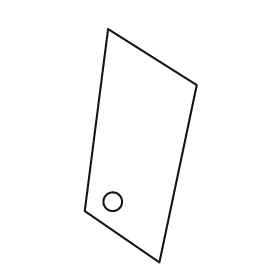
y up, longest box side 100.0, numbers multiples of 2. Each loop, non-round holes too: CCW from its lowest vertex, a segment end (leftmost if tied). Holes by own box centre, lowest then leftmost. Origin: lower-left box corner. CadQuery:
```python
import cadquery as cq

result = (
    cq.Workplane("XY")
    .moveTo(32.0, 0.0)
    .lineTo(48.0, 76.0)
    .lineTo(10.0, 100.0)
    .lineTo(0.0, 22.0)
    .close()
    .moveTo(12.0, 26.0)
    .circle(4.0)
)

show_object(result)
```